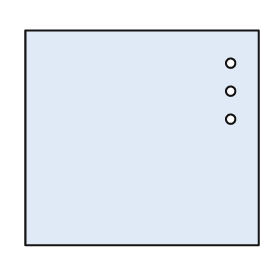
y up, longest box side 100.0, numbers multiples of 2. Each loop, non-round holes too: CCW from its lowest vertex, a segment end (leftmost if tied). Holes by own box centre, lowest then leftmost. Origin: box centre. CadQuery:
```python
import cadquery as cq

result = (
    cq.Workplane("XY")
    .moveTo(-50.0, -46.0)
    .lineTo(50.0, -46.0)
    .lineTo(50.0, 46.0)
    .lineTo(-50.0, 46.0)
    .close()
    .moveTo(38.0, 8.0)
    .circle(2.0)
    .moveTo(38.0, 20.0)
    .circle(2.0)
    .moveTo(38.0, 32.0)
    .circle(2.0)
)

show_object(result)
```